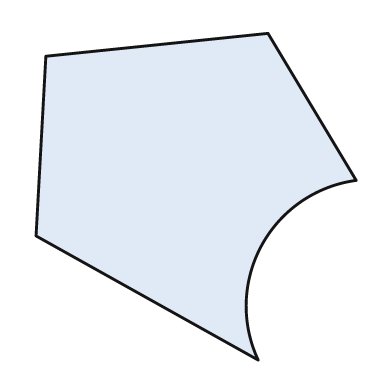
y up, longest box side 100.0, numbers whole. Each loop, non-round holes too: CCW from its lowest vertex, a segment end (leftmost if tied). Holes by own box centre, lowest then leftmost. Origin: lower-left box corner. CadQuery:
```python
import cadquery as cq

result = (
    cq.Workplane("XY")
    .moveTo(68.0, 0.0)
    .threePointArc((69.0, 35.0), (98.0, 55.0))
    .lineTo(71.0, 100.0)
    .lineTo(3.0, 93.0)
    .lineTo(0.0, 38.0)
    .close()
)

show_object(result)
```